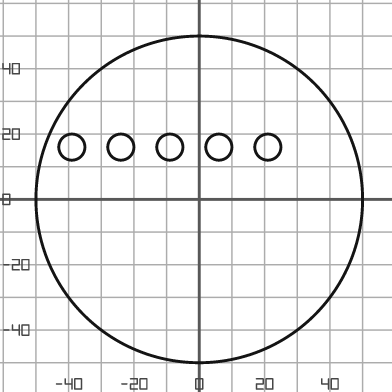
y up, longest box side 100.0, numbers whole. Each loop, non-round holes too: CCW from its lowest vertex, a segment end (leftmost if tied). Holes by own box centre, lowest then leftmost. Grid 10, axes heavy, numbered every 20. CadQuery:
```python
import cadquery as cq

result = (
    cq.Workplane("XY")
    .moveTo(0.0, 0.0)
    .circle(50.0)
    .moveTo(-39.0, 16.0)
    .circle(4.0)
    .moveTo(-24.0, 16.0)
    .circle(4.0)
    .moveTo(-9.0, 16.0)
    .circle(4.0)
    .moveTo(6.0, 16.0)
    .circle(4.0)
    .moveTo(21.0, 16.0)
    .circle(4.0)
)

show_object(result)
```